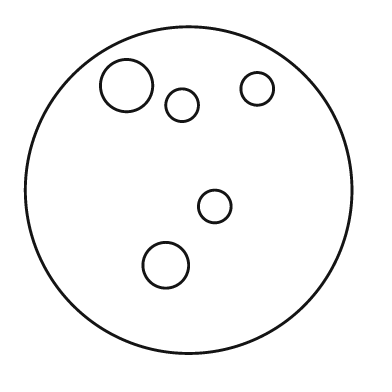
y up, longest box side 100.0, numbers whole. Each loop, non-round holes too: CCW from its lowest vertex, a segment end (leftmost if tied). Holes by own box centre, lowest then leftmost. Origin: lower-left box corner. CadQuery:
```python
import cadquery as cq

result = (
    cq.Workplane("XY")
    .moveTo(50.0, 50.0)
    .circle(50.0)
    .moveTo(43.0, 27.0)
    .circle(7.0)
    .moveTo(58.0, 45.0)
    .circle(5.0)
    .moveTo(48.0, 76.0)
    .circle(5.0)
    .moveTo(71.0, 81.0)
    .circle(5.0)
    .moveTo(31.0, 82.0)
    .circle(8.0)
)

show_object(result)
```